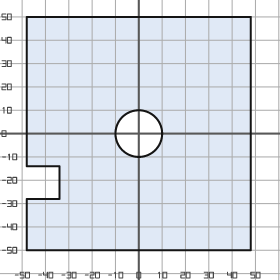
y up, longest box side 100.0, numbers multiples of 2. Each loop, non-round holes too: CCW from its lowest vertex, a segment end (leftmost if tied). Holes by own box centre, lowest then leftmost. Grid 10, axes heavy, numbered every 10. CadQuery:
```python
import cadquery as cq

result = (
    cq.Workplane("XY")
    .moveTo(-48.0, -50.0)
    .lineTo(48.0, -50.0)
    .lineTo(48.0, 50.0)
    .lineTo(-48.0, 50.0)
    .lineTo(-48.0, -14.0)
    .lineTo(-34.0, -14.0)
    .lineTo(-34.0, -28.0)
    .lineTo(-48.0, -28.0)
    .close()
    .moveTo(0.0, 0.0)
    .circle(10.0)
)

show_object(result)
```